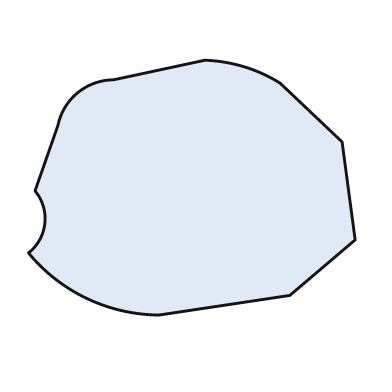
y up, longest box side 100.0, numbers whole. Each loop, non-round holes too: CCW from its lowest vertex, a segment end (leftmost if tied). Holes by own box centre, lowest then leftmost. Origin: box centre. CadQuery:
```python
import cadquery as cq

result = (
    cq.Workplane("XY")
    .moveTo(-10.0, -39.0)
    .lineTo(30.0, -33.0)
    .lineTo(50.0, -16.0)
    .lineTo(46.0, 14.0)
    .lineTo(27.0, 32.0)
    .threePointArc((16.0, 37.0), (4.0, 39.0))
    .lineTo(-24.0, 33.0)
    .threePointArc((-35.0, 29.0), (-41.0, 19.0))
    .lineTo(-48.0, -1.0)
    .threePointArc((-45.0, -11.0), (-50.0, -20.0))
    .threePointArc((-32.0, -34.0), (-10.0, -39.0))
    .close()
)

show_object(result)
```